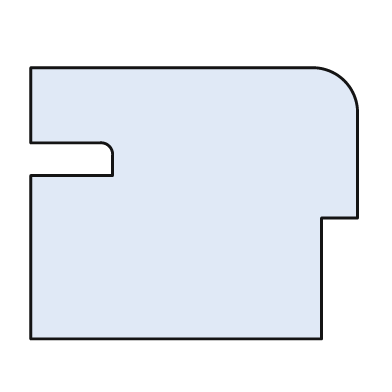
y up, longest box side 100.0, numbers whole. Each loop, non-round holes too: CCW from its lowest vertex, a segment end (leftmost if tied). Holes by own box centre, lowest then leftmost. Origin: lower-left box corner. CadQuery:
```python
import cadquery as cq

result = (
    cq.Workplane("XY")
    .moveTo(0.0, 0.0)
    .lineTo(89.0, 0.0)
    .lineTo(89.0, 37.0)
    .lineTo(100.0, 37.0)
    .lineTo(100.0, 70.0)
    .threePointArc((96.0, 79.0), (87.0, 83.0))
    .lineTo(0.0, 83.0)
    .lineTo(0.0, 60.0)
    .lineTo(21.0, 60.0)
    .threePointArc((24.0, 59.0), (25.0, 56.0))
    .lineTo(25.0, 50.0)
    .lineTo(0.0, 50.0)
    .close()
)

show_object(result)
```